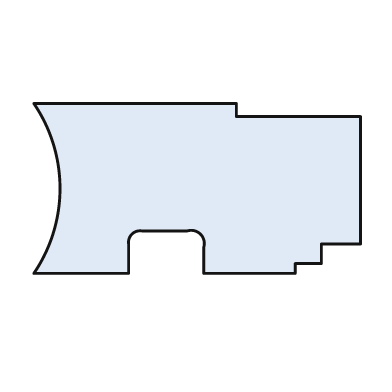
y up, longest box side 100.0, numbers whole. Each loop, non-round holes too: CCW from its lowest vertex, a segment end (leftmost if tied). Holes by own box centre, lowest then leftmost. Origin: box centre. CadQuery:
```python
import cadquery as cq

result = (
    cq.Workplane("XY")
    .moveTo(-50.0, -26.0)
    .lineTo(-21.0, -26.0)
    .lineTo(-21.0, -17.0)
    .threePointArc((-20.0, -14.0), (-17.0, -13.0))
    .lineTo(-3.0, -13.0)
    .threePointArc((1.0, -14.0), (2.0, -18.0))
    .lineTo(2.0, -26.0)
    .lineTo(30.0, -26.0)
    .lineTo(30.0, -23.0)
    .lineTo(38.0, -23.0)
    .lineTo(38.0, -17.0)
    .lineTo(50.0, -17.0)
    .lineTo(50.0, 22.0)
    .lineTo(12.0, 22.0)
    .lineTo(12.0, 26.0)
    .lineTo(-50.0, 26.0)
    .threePointArc((-42.0, 0.0), (-50.0, -26.0))
    .close()
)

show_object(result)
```